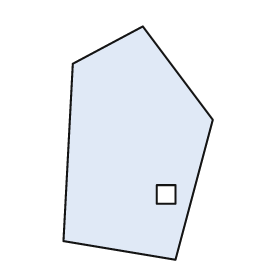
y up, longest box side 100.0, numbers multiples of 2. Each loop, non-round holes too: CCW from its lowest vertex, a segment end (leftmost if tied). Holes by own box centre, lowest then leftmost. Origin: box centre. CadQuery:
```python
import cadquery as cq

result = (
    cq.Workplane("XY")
    .moveTo(16.0, -50.0)
    .lineTo(32.0, 10.0)
    .lineTo(2.0, 50.0)
    .lineTo(-28.0, 34.0)
    .lineTo(-32.0, -42.0)
    .close()
    .moveTo(8.0, -26.0)
    .lineTo(16.0, -26.0)
    .lineTo(16.0, -18.0)
    .lineTo(8.0, -18.0)
    .close()
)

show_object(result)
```